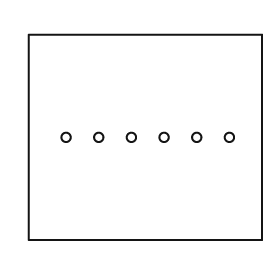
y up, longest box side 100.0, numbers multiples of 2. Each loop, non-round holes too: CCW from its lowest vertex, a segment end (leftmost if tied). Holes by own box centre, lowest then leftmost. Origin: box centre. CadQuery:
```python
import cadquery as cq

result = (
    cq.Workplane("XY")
    .moveTo(-50.0, -44.0)
    .lineTo(50.0, -44.0)
    .lineTo(50.0, 44.0)
    .lineTo(-50.0, 44.0)
    .close()
    .moveTo(-34.0, 0.0)
    .circle(2.0)
    .moveTo(-20.0, 0.0)
    .circle(2.0)
    .moveTo(-6.0, 0.0)
    .circle(2.0)
    .moveTo(8.0, 0.0)
    .circle(2.0)
    .moveTo(22.0, 0.0)
    .circle(2.0)
    .moveTo(36.0, 0.0)
    .circle(2.0)
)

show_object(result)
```